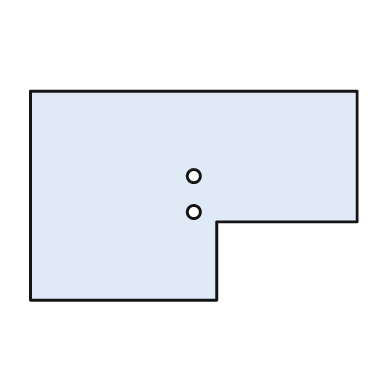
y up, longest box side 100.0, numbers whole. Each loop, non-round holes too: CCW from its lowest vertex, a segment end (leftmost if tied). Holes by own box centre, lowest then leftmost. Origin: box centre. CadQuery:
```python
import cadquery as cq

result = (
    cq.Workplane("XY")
    .moveTo(-50.0, -32.0)
    .lineTo(7.0, -32.0)
    .lineTo(7.0, -8.0)
    .lineTo(50.0, -8.0)
    .lineTo(50.0, 32.0)
    .lineTo(-50.0, 32.0)
    .close()
    .moveTo(0.0, -5.0)
    .circle(2.0)
    .moveTo(0.0, 6.0)
    .circle(2.0)
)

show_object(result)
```